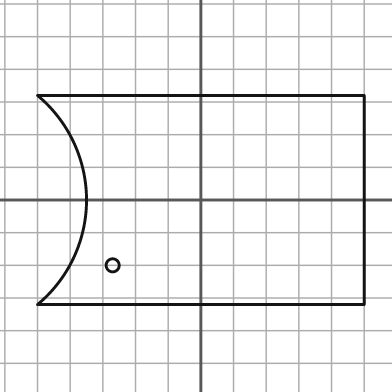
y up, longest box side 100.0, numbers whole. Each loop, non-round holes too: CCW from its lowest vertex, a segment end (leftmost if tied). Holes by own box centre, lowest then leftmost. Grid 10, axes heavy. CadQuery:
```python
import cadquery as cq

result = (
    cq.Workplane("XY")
    .moveTo(-50.0, -32.0)
    .lineTo(50.0, -32.0)
    .lineTo(50.0, 32.0)
    .lineTo(-50.0, 32.0)
    .threePointArc((-35.0, 0.0), (-50.0, -32.0))
    .close()
    .moveTo(-27.0, -20.0)
    .circle(2.0)
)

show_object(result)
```